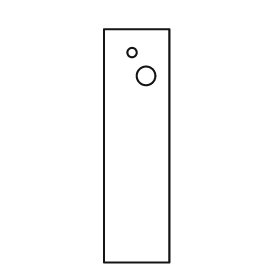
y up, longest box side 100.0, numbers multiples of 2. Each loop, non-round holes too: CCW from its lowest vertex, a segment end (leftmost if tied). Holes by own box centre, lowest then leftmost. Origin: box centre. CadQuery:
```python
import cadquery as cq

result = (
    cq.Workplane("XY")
    .moveTo(-14.0, -50.0)
    .lineTo(14.0, -50.0)
    .lineTo(14.0, 50.0)
    .lineTo(-14.0, 50.0)
    .close()
    .moveTo(4.0, 30.0)
    .circle(4.0)
    .moveTo(-2.0, 40.0)
    .circle(2.0)
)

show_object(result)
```